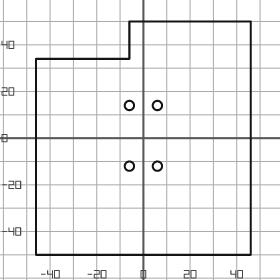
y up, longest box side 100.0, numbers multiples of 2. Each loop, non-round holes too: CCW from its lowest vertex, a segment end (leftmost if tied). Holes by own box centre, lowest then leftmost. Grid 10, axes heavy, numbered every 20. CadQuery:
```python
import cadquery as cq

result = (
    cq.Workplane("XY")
    .moveTo(-46.0, -50.0)
    .lineTo(46.0, -50.0)
    .lineTo(46.0, 50.0)
    .lineTo(-6.0, 50.0)
    .lineTo(-6.0, 34.0)
    .lineTo(-46.0, 34.0)
    .close()
    .moveTo(-6.0, -12.0)
    .circle(2.0)
    .moveTo(6.0, -12.0)
    .circle(2.0)
    .moveTo(-6.0, 14.0)
    .circle(2.0)
    .moveTo(6.0, 14.0)
    .circle(2.0)
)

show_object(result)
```